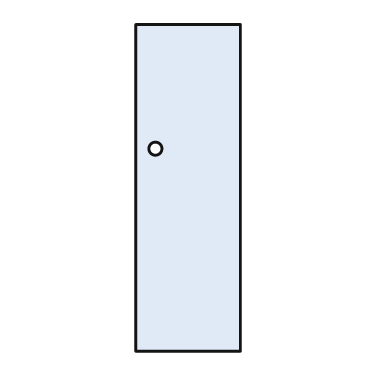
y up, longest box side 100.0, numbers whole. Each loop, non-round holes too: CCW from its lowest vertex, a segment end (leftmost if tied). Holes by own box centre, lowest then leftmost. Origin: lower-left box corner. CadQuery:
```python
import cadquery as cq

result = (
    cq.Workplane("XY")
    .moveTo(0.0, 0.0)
    .lineTo(32.0, 0.0)
    .lineTo(32.0, 100.0)
    .lineTo(0.0, 100.0)
    .close()
    .moveTo(6.0, 62.0)
    .circle(2.0)
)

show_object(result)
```